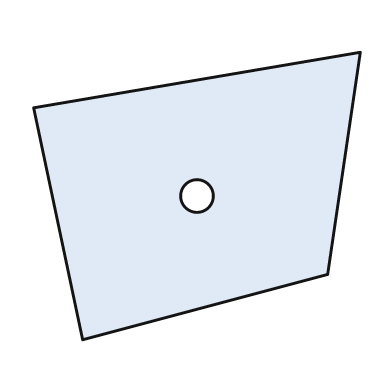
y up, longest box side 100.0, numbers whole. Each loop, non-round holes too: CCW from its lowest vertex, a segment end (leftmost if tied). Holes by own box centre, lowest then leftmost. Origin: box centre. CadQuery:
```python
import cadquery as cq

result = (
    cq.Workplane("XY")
    .moveTo(-35.0, -44.0)
    .lineTo(40.0, -24.0)
    .lineTo(50.0, 44.0)
    .lineTo(-50.0, 27.0)
    .close()
    .moveTo(0.0, 0.0)
    .circle(5.0)
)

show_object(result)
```